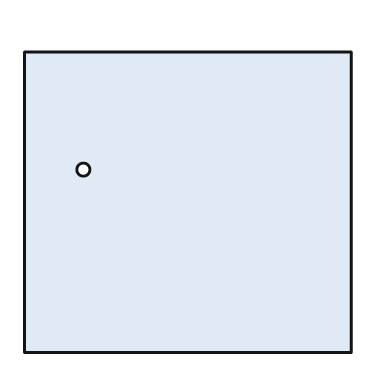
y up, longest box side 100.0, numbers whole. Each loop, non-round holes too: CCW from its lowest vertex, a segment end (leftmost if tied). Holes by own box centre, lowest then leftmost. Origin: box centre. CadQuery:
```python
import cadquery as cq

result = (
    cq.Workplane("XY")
    .moveTo(-50.0, -46.0)
    .lineTo(50.0, -46.0)
    .lineTo(50.0, 46.0)
    .lineTo(-50.0, 46.0)
    .close()
    .moveTo(-32.0, 10.0)
    .circle(2.0)
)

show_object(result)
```